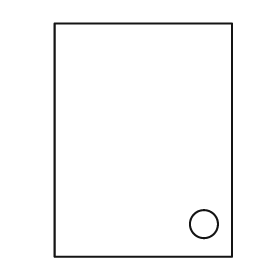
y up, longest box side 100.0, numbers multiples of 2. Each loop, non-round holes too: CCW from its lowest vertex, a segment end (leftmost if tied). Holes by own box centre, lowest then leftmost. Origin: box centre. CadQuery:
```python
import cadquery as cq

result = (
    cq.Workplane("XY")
    .moveTo(-38.0, -50.0)
    .lineTo(38.0, -50.0)
    .lineTo(38.0, 50.0)
    .lineTo(-38.0, 50.0)
    .close()
    .moveTo(26.0, -36.0)
    .circle(6.0)
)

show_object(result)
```